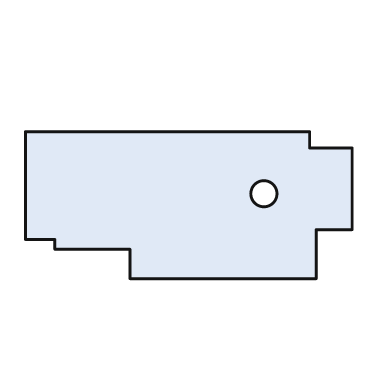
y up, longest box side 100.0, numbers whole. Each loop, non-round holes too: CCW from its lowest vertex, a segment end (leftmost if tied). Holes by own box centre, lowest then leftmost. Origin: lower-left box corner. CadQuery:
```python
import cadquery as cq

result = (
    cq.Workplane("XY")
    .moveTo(32.0, 0.0)
    .lineTo(89.0, 0.0)
    .lineTo(89.0, 15.0)
    .lineTo(100.0, 15.0)
    .lineTo(100.0, 40.0)
    .lineTo(87.0, 40.0)
    .lineTo(87.0, 45.0)
    .lineTo(0.0, 45.0)
    .lineTo(0.0, 12.0)
    .lineTo(9.0, 12.0)
    .lineTo(9.0, 9.0)
    .lineTo(32.0, 9.0)
    .close()
    .moveTo(73.0, 26.0)
    .circle(4.0)
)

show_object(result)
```